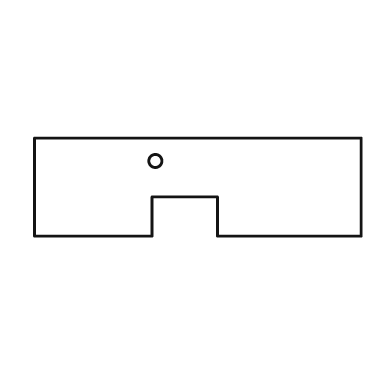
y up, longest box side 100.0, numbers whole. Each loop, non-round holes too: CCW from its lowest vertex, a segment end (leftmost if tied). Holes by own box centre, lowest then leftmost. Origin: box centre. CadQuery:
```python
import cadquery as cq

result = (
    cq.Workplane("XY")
    .moveTo(-50.0, -15.0)
    .lineTo(-14.0, -15.0)
    .lineTo(-14.0, -3.0)
    .lineTo(6.0, -3.0)
    .lineTo(6.0, -15.0)
    .lineTo(50.0, -15.0)
    .lineTo(50.0, 15.0)
    .lineTo(-50.0, 15.0)
    .close()
    .moveTo(-13.0, 8.0)
    .circle(2.0)
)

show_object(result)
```